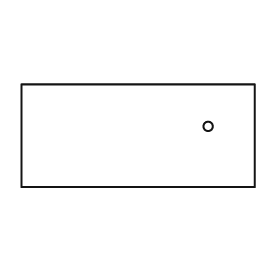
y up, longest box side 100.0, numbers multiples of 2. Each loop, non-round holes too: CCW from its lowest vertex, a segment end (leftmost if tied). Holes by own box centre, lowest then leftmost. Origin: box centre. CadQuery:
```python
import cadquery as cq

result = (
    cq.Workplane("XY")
    .moveTo(-50.0, -22.0)
    .lineTo(50.0, -22.0)
    .lineTo(50.0, 22.0)
    .lineTo(-50.0, 22.0)
    .close()
    .moveTo(30.0, 4.0)
    .circle(2.0)
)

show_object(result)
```